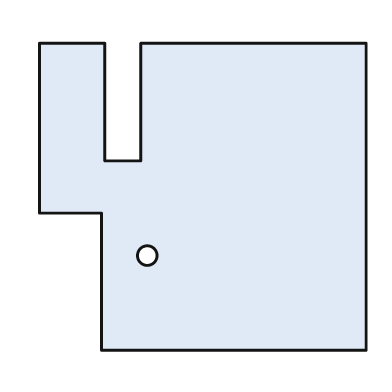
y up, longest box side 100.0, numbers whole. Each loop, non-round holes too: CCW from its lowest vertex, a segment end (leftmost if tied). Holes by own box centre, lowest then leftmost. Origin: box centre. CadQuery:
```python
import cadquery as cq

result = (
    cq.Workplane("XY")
    .moveTo(-31.0, -47.0)
    .lineTo(50.0, -47.0)
    .lineTo(50.0, 47.0)
    .lineTo(-19.0, 47.0)
    .lineTo(-19.0, 11.0)
    .lineTo(-30.0, 11.0)
    .lineTo(-30.0, 47.0)
    .lineTo(-50.0, 47.0)
    .lineTo(-50.0, -5.0)
    .lineTo(-31.0, -5.0)
    .close()
    .moveTo(-17.0, -18.0)
    .circle(3.0)
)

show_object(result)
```